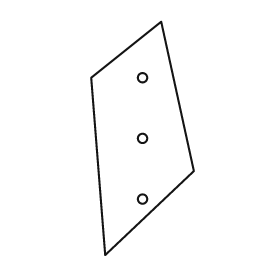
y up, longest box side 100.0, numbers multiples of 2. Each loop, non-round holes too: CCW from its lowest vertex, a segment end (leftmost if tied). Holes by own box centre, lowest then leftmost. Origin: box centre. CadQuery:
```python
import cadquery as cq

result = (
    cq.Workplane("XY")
    .moveTo(-16.0, -50.0)
    .lineTo(22.0, -14.0)
    .lineTo(8.0, 50.0)
    .lineTo(-22.0, 26.0)
    .close()
    .moveTo(0.0, -26.0)
    .circle(2.0)
    .moveTo(0.0, 0.0)
    .circle(2.0)
    .moveTo(0.0, 26.0)
    .circle(2.0)
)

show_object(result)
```